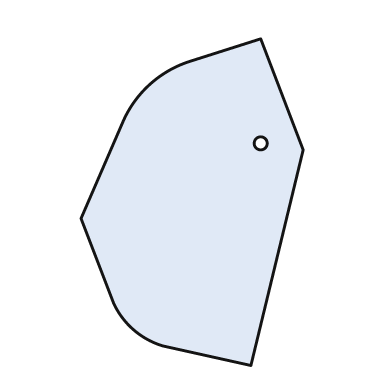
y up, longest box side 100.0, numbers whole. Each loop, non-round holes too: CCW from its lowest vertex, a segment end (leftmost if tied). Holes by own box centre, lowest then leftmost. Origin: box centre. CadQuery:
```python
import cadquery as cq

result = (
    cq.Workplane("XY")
    .moveTo(18.0, -50.0)
    .lineTo(34.0, 16.0)
    .lineTo(21.0, 50.0)
    .lineTo(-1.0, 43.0)
    .threePointArc((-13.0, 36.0), (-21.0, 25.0))
    .lineTo(-34.0, -5.0)
    .lineTo(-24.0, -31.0)
    .threePointArc((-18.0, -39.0), (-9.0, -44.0))
    .close()
    .moveTo(21.0, 18.0)
    .circle(2.0)
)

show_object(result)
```